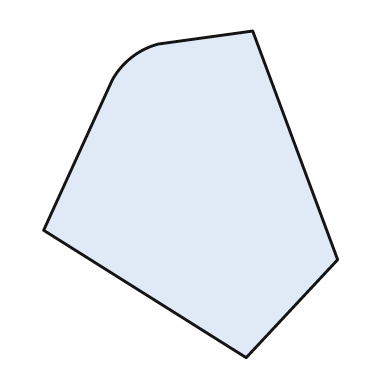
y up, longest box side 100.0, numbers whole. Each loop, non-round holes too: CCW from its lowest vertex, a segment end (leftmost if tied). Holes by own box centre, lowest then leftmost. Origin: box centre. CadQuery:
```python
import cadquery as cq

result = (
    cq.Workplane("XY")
    .moveTo(17.0, -50.0)
    .lineTo(45.0, -20.0)
    .lineTo(19.0, 50.0)
    .lineTo(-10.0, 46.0)
    .threePointArc((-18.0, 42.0), (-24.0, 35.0))
    .lineTo(-45.0, -11.0)
    .close()
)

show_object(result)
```